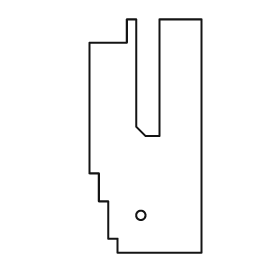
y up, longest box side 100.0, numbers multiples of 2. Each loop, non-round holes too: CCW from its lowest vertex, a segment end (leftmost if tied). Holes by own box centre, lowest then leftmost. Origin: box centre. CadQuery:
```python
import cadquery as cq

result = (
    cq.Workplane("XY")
    .moveTo(-12.0, -50.0)
    .lineTo(24.0, -50.0)
    .lineTo(24.0, 50.0)
    .lineTo(6.0, 50.0)
    .lineTo(6.0, 0.0)
    .lineTo(0.0, 0.0)
    .lineTo(-4.0, 4.0)
    .lineTo(-4.0, 50.0)
    .lineTo(-8.0, 50.0)
    .lineTo(-8.0, 40.0)
    .lineTo(-24.0, 40.0)
    .lineTo(-24.0, -16.0)
    .lineTo(-20.0, -16.0)
    .lineTo(-20.0, -28.0)
    .lineTo(-16.0, -28.0)
    .lineTo(-16.0, -44.0)
    .lineTo(-12.0, -44.0)
    .close()
    .moveTo(-2.0, -34.0)
    .circle(2.0)
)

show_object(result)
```